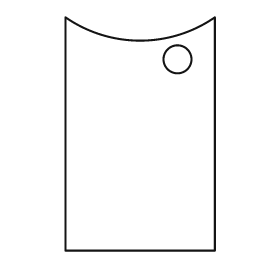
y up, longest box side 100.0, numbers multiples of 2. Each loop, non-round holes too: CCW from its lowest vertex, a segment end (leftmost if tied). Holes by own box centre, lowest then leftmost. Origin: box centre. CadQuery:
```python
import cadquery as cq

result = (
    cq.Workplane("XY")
    .moveTo(-32.0, -50.0)
    .lineTo(32.0, -50.0)
    .lineTo(32.0, 50.0)
    .threePointArc((0.0, 40.0), (-32.0, 50.0))
    .close()
    .moveTo(16.0, 32.0)
    .circle(6.0)
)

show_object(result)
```